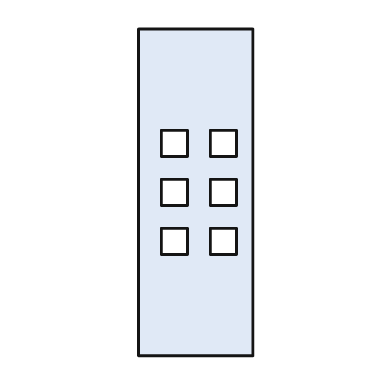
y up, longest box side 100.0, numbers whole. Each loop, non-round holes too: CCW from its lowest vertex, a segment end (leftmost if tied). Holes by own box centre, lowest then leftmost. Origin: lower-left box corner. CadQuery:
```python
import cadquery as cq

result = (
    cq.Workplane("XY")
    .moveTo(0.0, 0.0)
    .lineTo(35.0, 0.0)
    .lineTo(35.0, 100.0)
    .lineTo(0.0, 100.0)
    .close()
    .moveTo(7.0, 31.0)
    .lineTo(15.0, 31.0)
    .lineTo(15.0, 39.0)
    .lineTo(7.0, 39.0)
    .close()
    .moveTo(22.0, 31.0)
    .lineTo(30.0, 31.0)
    .lineTo(30.0, 39.0)
    .lineTo(22.0, 39.0)
    .close()
    .moveTo(7.0, 46.0)
    .lineTo(15.0, 46.0)
    .lineTo(15.0, 54.0)
    .lineTo(7.0, 54.0)
    .close()
    .moveTo(22.0, 46.0)
    .lineTo(30.0, 46.0)
    .lineTo(30.0, 54.0)
    .lineTo(22.0, 54.0)
    .close()
    .moveTo(7.0, 61.0)
    .lineTo(15.0, 61.0)
    .lineTo(15.0, 69.0)
    .lineTo(7.0, 69.0)
    .close()
    .moveTo(22.0, 61.0)
    .lineTo(30.0, 61.0)
    .lineTo(30.0, 69.0)
    .lineTo(22.0, 69.0)
    .close()
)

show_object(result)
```